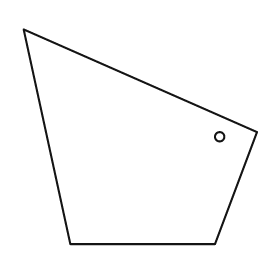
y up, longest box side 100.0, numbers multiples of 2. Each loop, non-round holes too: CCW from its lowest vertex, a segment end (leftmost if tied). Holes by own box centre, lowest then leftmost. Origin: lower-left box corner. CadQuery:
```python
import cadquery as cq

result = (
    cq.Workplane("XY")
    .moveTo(20.0, 0.0)
    .lineTo(82.0, 0.0)
    .lineTo(100.0, 48.0)
    .lineTo(0.0, 92.0)
    .close()
    .moveTo(84.0, 46.0)
    .circle(2.0)
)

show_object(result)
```